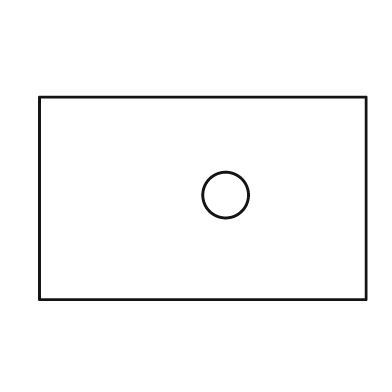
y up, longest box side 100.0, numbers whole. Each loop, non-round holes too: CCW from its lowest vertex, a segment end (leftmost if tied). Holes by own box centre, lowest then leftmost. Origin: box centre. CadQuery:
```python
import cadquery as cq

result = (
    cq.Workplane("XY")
    .moveTo(-50.0, -31.0)
    .lineTo(50.0, -31.0)
    .lineTo(50.0, 31.0)
    .lineTo(-50.0, 31.0)
    .close()
    .moveTo(7.0, 1.0)
    .circle(7.0)
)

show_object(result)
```